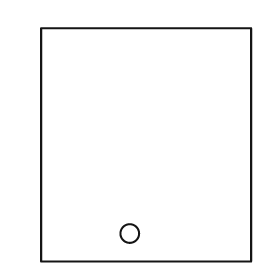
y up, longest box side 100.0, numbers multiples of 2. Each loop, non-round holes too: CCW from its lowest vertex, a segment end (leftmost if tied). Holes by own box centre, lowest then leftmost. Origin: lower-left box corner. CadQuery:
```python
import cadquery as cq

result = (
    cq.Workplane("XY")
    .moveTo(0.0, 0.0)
    .lineTo(90.0, 0.0)
    .lineTo(90.0, 100.0)
    .lineTo(0.0, 100.0)
    .close()
    .moveTo(38.0, 12.0)
    .circle(4.0)
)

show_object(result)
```